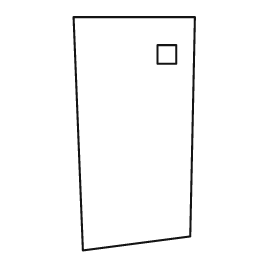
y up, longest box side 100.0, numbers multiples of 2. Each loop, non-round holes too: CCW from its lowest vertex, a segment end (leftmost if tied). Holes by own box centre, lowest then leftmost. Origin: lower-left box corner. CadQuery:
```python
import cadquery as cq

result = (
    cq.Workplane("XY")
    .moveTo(4.0, 0.0)
    .lineTo(50.0, 6.0)
    .lineTo(52.0, 100.0)
    .lineTo(0.0, 100.0)
    .close()
    .moveTo(36.0, 80.0)
    .lineTo(44.0, 80.0)
    .lineTo(44.0, 88.0)
    .lineTo(36.0, 88.0)
    .close()
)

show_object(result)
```